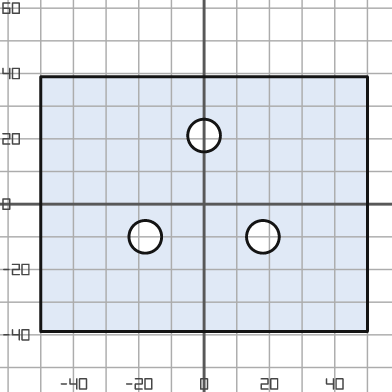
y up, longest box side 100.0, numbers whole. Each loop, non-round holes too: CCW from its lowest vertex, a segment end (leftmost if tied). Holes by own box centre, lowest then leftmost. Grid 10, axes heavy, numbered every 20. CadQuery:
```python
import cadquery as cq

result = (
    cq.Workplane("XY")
    .moveTo(-50.0, -39.0)
    .lineTo(50.0, -39.0)
    .lineTo(50.0, 39.0)
    .lineTo(-50.0, 39.0)
    .close()
    .moveTo(-18.0, -10.0)
    .circle(5.0)
    .moveTo(18.0, -10.0)
    .circle(5.0)
    .moveTo(0.0, 21.0)
    .circle(5.0)
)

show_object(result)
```